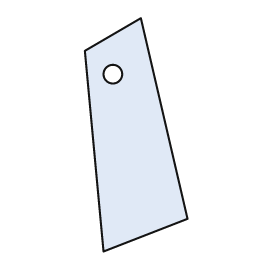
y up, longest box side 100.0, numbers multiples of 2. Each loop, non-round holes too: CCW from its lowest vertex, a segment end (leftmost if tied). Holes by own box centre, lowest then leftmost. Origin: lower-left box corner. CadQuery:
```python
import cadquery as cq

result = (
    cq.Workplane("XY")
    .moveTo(8.0, 0.0)
    .lineTo(44.0, 14.0)
    .lineTo(24.0, 100.0)
    .lineTo(0.0, 86.0)
    .close()
    .moveTo(12.0, 76.0)
    .circle(4.0)
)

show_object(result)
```